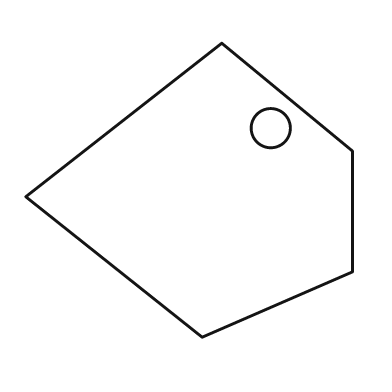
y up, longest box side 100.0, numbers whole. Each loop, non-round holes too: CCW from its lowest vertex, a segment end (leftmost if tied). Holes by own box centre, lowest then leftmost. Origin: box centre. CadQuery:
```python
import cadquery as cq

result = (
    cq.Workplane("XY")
    .moveTo(4.0, -45.0)
    .lineTo(50.0, -25.0)
    .lineTo(50.0, 12.0)
    .lineTo(10.0, 45.0)
    .lineTo(-50.0, -2.0)
    .close()
    .moveTo(25.0, 19.0)
    .circle(6.0)
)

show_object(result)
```